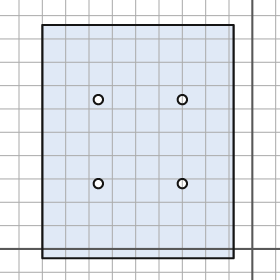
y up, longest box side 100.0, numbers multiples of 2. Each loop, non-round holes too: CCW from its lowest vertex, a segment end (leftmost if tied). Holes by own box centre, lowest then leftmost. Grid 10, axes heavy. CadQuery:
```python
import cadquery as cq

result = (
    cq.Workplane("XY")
    .moveTo(-90.0, -4.0)
    .lineTo(-8.0, -4.0)
    .lineTo(-8.0, 96.0)
    .lineTo(-90.0, 96.0)
    .close()
    .moveTo(-66.0, 28.0)
    .circle(2.0)
    .moveTo(-30.0, 28.0)
    .circle(2.0)
    .moveTo(-66.0, 64.0)
    .circle(2.0)
    .moveTo(-30.0, 64.0)
    .circle(2.0)
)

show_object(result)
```